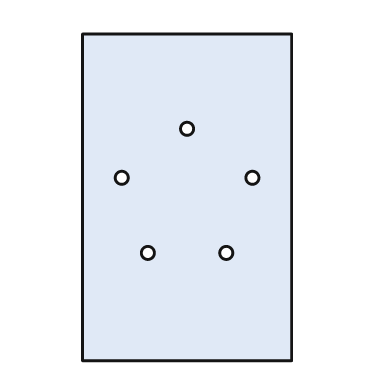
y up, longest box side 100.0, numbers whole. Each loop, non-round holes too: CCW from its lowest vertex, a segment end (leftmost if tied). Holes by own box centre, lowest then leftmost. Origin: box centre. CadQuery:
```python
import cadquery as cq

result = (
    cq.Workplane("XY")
    .moveTo(-32.0, -50.0)
    .lineTo(32.0, -50.0)
    .lineTo(32.0, 50.0)
    .lineTo(-32.0, 50.0)
    .close()
    .moveTo(-12.0, -17.0)
    .circle(2.0)
    .moveTo(12.0, -17.0)
    .circle(2.0)
    .moveTo(-20.0, 6.0)
    .circle(2.0)
    .moveTo(20.0, 6.0)
    .circle(2.0)
    .moveTo(0.0, 21.0)
    .circle(2.0)
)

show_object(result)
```